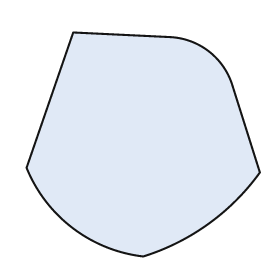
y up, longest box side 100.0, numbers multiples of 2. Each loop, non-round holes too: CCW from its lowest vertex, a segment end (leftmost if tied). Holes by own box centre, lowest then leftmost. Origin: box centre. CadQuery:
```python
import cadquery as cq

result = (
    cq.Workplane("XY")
    .moveTo(0.0, -48.0)
    .threePointArc((28.0, -34.0), (50.0, -12.0))
    .lineTo(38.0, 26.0)
    .threePointArc((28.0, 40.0), (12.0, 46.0))
    .lineTo(-30.0, 48.0)
    .lineTo(-50.0, -10.0)
    .threePointArc((-30.0, -36.0), (0.0, -48.0))
    .close()
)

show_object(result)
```